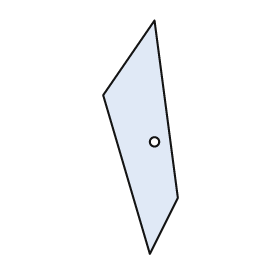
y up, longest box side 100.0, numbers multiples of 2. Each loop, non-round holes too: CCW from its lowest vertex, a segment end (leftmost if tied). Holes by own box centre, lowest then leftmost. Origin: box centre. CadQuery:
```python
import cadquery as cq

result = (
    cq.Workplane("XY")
    .moveTo(4.0, -50.0)
    .lineTo(16.0, -26.0)
    .lineTo(6.0, 50.0)
    .lineTo(-16.0, 18.0)
    .close()
    .moveTo(6.0, -2.0)
    .circle(2.0)
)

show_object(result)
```